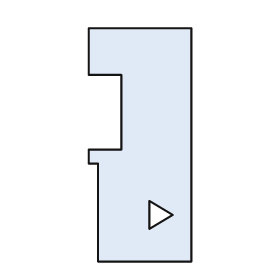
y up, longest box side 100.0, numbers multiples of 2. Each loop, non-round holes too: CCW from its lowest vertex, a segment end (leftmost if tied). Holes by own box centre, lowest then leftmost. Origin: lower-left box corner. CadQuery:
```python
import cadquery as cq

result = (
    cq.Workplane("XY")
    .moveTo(4.0, 0.0)
    .lineTo(44.0, 0.0)
    .lineTo(44.0, 100.0)
    .lineTo(0.0, 100.0)
    .lineTo(0.0, 80.0)
    .lineTo(14.0, 80.0)
    .lineTo(14.0, 48.0)
    .lineTo(0.0, 48.0)
    .lineTo(0.0, 42.0)
    .lineTo(4.0, 42.0)
    .close()
    .moveTo(26.0, 14.0)
    .lineTo(36.0, 20.0)
    .lineTo(26.0, 26.0)
    .close()
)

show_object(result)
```